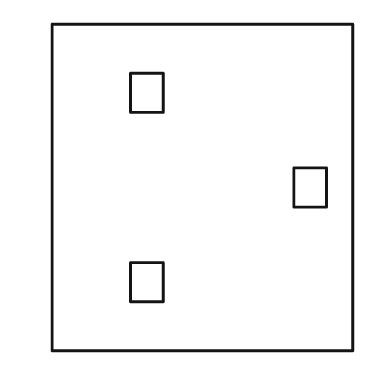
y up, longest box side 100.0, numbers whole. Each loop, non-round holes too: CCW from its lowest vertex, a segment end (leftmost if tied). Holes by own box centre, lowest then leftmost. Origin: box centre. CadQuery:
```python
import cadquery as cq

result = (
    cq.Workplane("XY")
    .moveTo(-46.0, -50.0)
    .lineTo(46.0, -50.0)
    .lineTo(46.0, 50.0)
    .lineTo(-46.0, 50.0)
    .close()
    .moveTo(-22.0, -35.0)
    .lineTo(-12.0, -35.0)
    .lineTo(-12.0, -23.0)
    .lineTo(-22.0, -23.0)
    .close()
    .moveTo(28.0, -6.0)
    .lineTo(38.0, -6.0)
    .lineTo(38.0, 6.0)
    .lineTo(28.0, 6.0)
    .close()
    .moveTo(-22.0, 23.0)
    .lineTo(-12.0, 23.0)
    .lineTo(-12.0, 35.0)
    .lineTo(-22.0, 35.0)
    .close()
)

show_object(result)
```